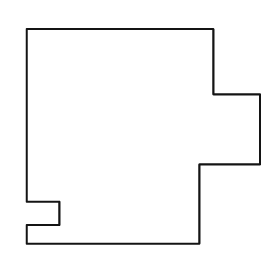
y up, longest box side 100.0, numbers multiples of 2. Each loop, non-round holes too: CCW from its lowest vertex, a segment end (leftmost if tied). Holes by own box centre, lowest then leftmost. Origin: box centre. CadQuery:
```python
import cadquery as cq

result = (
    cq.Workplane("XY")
    .moveTo(-50.0, -46.0)
    .lineTo(24.0, -46.0)
    .lineTo(24.0, -12.0)
    .lineTo(50.0, -12.0)
    .lineTo(50.0, 18.0)
    .lineTo(30.0, 18.0)
    .lineTo(30.0, 46.0)
    .lineTo(-50.0, 46.0)
    .lineTo(-50.0, -28.0)
    .lineTo(-36.0, -28.0)
    .lineTo(-36.0, -38.0)
    .lineTo(-50.0, -38.0)
    .close()
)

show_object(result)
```